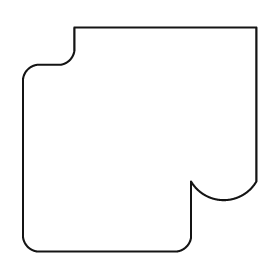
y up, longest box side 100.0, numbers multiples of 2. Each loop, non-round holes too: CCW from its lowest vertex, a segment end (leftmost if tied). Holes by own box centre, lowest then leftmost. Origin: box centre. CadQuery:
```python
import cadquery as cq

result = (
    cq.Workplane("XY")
    .moveTo(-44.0, -48.0)
    .lineTo(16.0, -48.0)
    .threePointArc((20.0, -46.0), (22.0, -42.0))
    .lineTo(22.0, -18.0)
    .threePointArc((36.0, -26.0), (50.0, -18.0))
    .lineTo(50.0, 48.0)
    .lineTo(-28.0, 48.0)
    .lineTo(-28.0, 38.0)
    .threePointArc((-30.0, 34.0), (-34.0, 32.0))
    .lineTo(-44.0, 32.0)
    .threePointArc((-48.0, 30.0), (-50.0, 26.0))
    .lineTo(-50.0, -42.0)
    .threePointArc((-48.0, -46.0), (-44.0, -48.0))
    .close()
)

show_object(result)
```